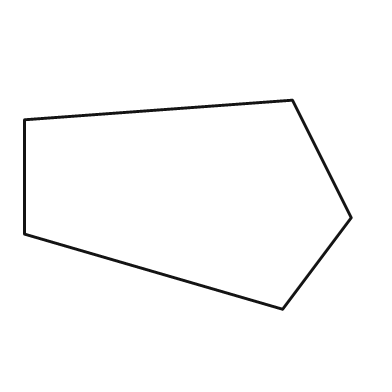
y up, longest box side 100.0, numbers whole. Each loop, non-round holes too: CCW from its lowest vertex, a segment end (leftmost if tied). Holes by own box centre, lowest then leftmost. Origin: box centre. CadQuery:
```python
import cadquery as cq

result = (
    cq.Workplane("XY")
    .moveTo(29.0, -32.0)
    .lineTo(50.0, -4.0)
    .lineTo(32.0, 32.0)
    .lineTo(-50.0, 26.0)
    .lineTo(-50.0, -9.0)
    .close()
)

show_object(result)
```